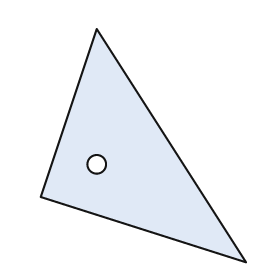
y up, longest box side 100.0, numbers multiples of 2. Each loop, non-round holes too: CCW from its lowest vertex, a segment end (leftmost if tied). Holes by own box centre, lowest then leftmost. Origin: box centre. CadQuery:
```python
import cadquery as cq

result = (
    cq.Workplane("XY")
    .moveTo(44.0, -50.0)
    .lineTo(-20.0, 50.0)
    .lineTo(-44.0, -22.0)
    .close()
    .moveTo(-20.0, -8.0)
    .circle(4.0)
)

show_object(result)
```